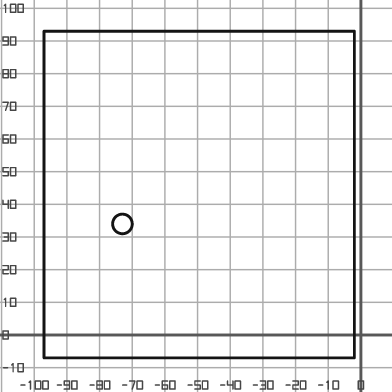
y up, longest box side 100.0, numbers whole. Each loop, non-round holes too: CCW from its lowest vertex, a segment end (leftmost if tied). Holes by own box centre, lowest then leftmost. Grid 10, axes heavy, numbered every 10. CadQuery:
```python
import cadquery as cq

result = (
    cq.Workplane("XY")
    .moveTo(-97.0, -7.0)
    .lineTo(-2.0, -7.0)
    .lineTo(-2.0, 93.0)
    .lineTo(-97.0, 93.0)
    .close()
    .moveTo(-73.0, 34.0)
    .circle(3.0)
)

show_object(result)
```